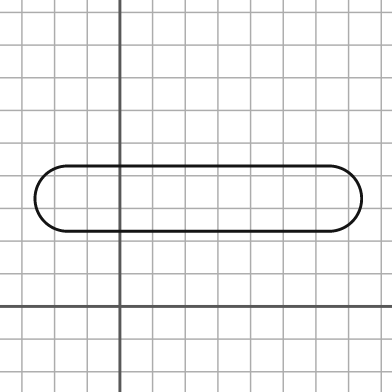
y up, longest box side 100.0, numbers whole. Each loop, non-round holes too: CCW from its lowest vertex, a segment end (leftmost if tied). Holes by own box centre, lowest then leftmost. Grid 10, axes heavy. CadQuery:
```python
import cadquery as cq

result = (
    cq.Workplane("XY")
    .moveTo(-16.0, 23.0)
    .lineTo(64.0, 23.0)
    .threePointArc((74.0, 33.0), (64.0, 43.0))
    .lineTo(-16.0, 43.0)
    .threePointArc((-26.0, 33.0), (-16.0, 23.0))
    .close()
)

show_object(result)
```